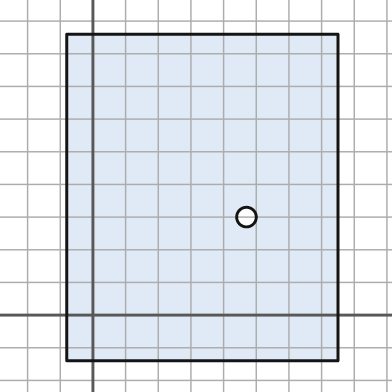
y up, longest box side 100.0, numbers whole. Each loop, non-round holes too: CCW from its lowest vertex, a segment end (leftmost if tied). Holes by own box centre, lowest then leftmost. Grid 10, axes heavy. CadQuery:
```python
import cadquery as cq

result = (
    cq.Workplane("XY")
    .moveTo(-8.0, -14.0)
    .lineTo(75.0, -14.0)
    .lineTo(75.0, 86.0)
    .lineTo(-8.0, 86.0)
    .close()
    .moveTo(47.0, 30.0)
    .circle(3.0)
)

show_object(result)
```